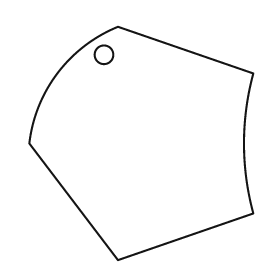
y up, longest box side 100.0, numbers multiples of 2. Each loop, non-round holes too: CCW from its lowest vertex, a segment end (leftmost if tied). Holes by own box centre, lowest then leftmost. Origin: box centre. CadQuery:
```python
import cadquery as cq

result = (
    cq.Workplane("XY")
    .moveTo(-10.0, -50.0)
    .lineTo(48.0, -30.0)
    .threePointArc((44.0, 0.0), (48.0, 30.0))
    .lineTo(-10.0, 50.0)
    .threePointArc((-36.0, 30.0), (-48.0, 0.0))
    .close()
    .moveTo(-16.0, 38.0)
    .circle(4.0)
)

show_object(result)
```